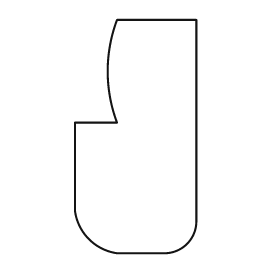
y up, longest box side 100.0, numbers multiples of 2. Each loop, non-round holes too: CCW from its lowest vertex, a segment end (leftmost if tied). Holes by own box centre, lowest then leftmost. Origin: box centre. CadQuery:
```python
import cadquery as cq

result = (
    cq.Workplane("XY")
    .moveTo(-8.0, -50.0)
    .lineTo(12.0, -50.0)
    .threePointArc((22.0, -46.0), (26.0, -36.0))
    .lineTo(26.0, 50.0)
    .lineTo(-8.0, 50.0)
    .threePointArc((-12.0, 28.0), (-8.0, 6.0))
    .lineTo(-26.0, 6.0)
    .lineTo(-26.0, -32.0)
    .threePointArc((-20.0, -44.0), (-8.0, -50.0))
    .close()
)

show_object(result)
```